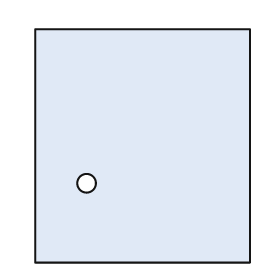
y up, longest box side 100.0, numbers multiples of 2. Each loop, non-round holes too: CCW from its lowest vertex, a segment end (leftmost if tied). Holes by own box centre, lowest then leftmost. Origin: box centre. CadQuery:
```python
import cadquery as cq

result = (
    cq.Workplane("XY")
    .moveTo(-46.0, -50.0)
    .lineTo(46.0, -50.0)
    .lineTo(46.0, 50.0)
    .lineTo(-46.0, 50.0)
    .close()
    .moveTo(-24.0, -16.0)
    .circle(4.0)
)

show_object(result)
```